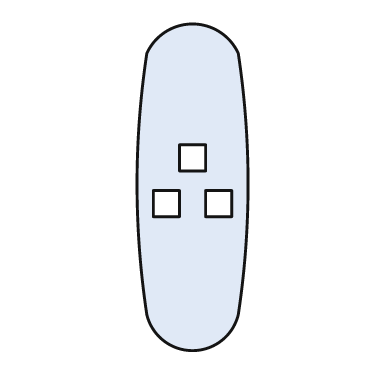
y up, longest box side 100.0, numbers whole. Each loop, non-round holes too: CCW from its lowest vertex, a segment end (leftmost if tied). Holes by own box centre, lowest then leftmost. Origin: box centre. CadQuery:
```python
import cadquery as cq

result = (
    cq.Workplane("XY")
    .moveTo(-14.0, -39.0)
    .threePointArc((0.0, -50.0), (14.0, -39.0))
    .threePointArc((17.0, 1.0), (14.0, 41.0))
    .threePointArc((0.0, 50.0), (-14.0, 41.0))
    .threePointArc((-17.0, 1.0), (-14.0, -39.0))
    .close()
    .moveTo(-12.0, -9.0)
    .lineTo(-4.0, -9.0)
    .lineTo(-4.0, -1.0)
    .lineTo(-12.0, -1.0)
    .close()
    .moveTo(4.0, -9.0)
    .lineTo(12.0, -9.0)
    .lineTo(12.0, -1.0)
    .lineTo(4.0, -1.0)
    .close()
    .moveTo(-4.0, 5.0)
    .lineTo(4.0, 5.0)
    .lineTo(4.0, 13.0)
    .lineTo(-4.0, 13.0)
    .close()
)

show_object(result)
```